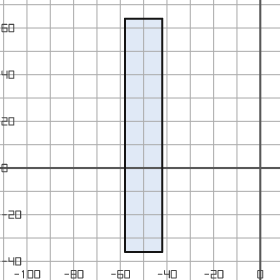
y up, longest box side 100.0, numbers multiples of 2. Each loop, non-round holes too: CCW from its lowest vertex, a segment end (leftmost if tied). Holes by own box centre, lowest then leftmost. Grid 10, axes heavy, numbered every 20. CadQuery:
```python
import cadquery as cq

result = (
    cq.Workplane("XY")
    .moveTo(-58.0, -36.0)
    .lineTo(-42.0, -36.0)
    .lineTo(-42.0, 64.0)
    .lineTo(-58.0, 64.0)
    .close()
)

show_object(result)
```